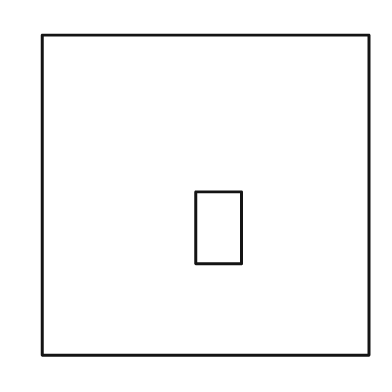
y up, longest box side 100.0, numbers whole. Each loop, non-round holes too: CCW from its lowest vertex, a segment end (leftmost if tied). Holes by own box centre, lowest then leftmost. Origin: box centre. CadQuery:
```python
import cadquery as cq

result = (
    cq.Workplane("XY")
    .moveTo(-50.0, -49.0)
    .lineTo(50.0, -49.0)
    .lineTo(50.0, 49.0)
    .lineTo(-50.0, 49.0)
    .close()
    .moveTo(-3.0, -21.0)
    .lineTo(11.0, -21.0)
    .lineTo(11.0, 1.0)
    .lineTo(-3.0, 1.0)
    .close()
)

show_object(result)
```